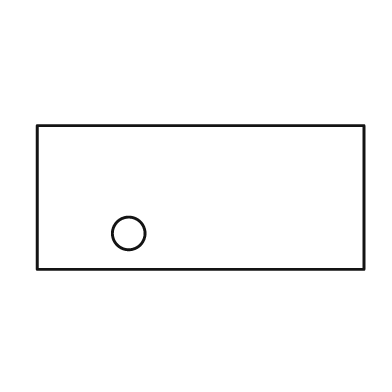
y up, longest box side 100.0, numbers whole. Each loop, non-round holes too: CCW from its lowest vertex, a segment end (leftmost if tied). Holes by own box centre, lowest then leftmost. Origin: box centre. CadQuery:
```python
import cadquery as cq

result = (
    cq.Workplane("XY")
    .moveTo(-50.0, -22.0)
    .lineTo(50.0, -22.0)
    .lineTo(50.0, 22.0)
    .lineTo(-50.0, 22.0)
    .close()
    .moveTo(-22.0, -11.0)
    .circle(5.0)
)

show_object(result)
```